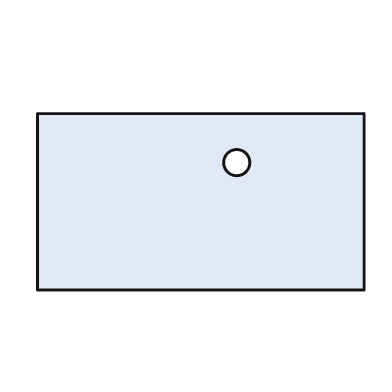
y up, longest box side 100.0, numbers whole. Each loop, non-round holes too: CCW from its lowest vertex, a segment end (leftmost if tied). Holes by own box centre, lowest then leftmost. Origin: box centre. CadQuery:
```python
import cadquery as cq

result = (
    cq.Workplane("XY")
    .moveTo(-50.0, -27.0)
    .lineTo(50.0, -27.0)
    .lineTo(50.0, 27.0)
    .lineTo(-50.0, 27.0)
    .close()
    .moveTo(11.0, 12.0)
    .circle(4.0)
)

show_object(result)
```